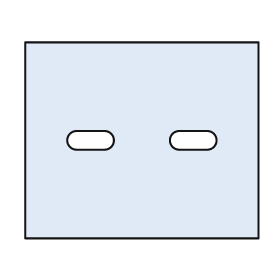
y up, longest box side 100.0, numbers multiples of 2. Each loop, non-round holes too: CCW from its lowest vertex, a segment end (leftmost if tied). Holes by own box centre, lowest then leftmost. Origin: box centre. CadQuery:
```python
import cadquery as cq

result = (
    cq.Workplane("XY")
    .moveTo(-50.0, -42.0)
    .lineTo(50.0, -42.0)
    .lineTo(50.0, 42.0)
    .lineTo(-50.0, 42.0)
    .close()
    .moveTo(-28.0, -4.0)
    .lineTo(-16.0, -4.0)
    .threePointArc((-12.0, 0.0), (-16.0, 4.0))
    .lineTo(-28.0, 4.0)
    .threePointArc((-32.0, 0.0), (-28.0, -4.0))
    .close()
    .moveTo(16.0, -4.0)
    .lineTo(28.0, -4.0)
    .threePointArc((32.0, 0.0), (28.0, 4.0))
    .lineTo(16.0, 4.0)
    .threePointArc((12.0, 0.0), (16.0, -4.0))
    .close()
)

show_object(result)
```